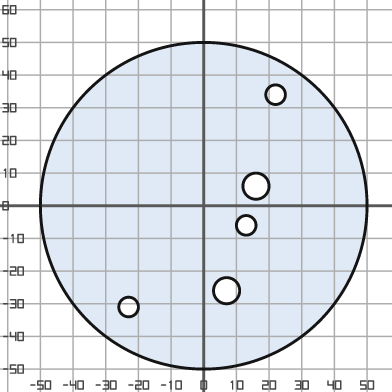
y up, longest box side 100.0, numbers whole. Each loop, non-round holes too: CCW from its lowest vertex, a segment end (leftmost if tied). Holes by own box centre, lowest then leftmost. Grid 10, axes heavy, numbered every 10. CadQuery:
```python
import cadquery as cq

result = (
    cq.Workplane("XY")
    .moveTo(0.0, 0.0)
    .circle(50.0)
    .moveTo(-23.0, -31.0)
    .circle(3.0)
    .moveTo(7.0, -26.0)
    .circle(4.0)
    .moveTo(13.0, -6.0)
    .circle(3.0)
    .moveTo(16.0, 6.0)
    .circle(4.0)
    .moveTo(22.0, 34.0)
    .circle(3.0)
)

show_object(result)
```